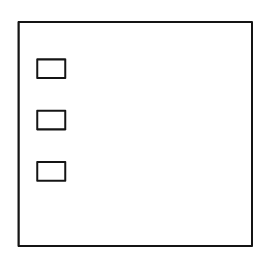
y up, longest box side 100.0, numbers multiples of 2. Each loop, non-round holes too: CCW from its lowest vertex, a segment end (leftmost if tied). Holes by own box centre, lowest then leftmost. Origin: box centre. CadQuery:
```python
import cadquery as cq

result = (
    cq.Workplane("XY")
    .moveTo(-50.0, -48.0)
    .lineTo(50.0, -48.0)
    .lineTo(50.0, 48.0)
    .lineTo(-50.0, 48.0)
    .close()
    .moveTo(-42.0, -20.0)
    .lineTo(-30.0, -20.0)
    .lineTo(-30.0, -12.0)
    .lineTo(-42.0, -12.0)
    .close()
    .moveTo(-42.0, 2.0)
    .lineTo(-30.0, 2.0)
    .lineTo(-30.0, 10.0)
    .lineTo(-42.0, 10.0)
    .close()
    .moveTo(-42.0, 24.0)
    .lineTo(-30.0, 24.0)
    .lineTo(-30.0, 32.0)
    .lineTo(-42.0, 32.0)
    .close()
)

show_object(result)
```